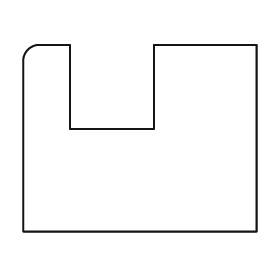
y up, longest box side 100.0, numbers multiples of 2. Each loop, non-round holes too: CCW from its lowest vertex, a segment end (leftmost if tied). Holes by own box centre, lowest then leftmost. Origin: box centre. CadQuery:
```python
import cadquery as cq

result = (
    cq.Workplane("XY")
    .moveTo(-50.0, -40.0)
    .lineTo(50.0, -40.0)
    .lineTo(50.0, 40.0)
    .lineTo(6.0, 40.0)
    .lineTo(6.0, 4.0)
    .lineTo(-30.0, 4.0)
    .lineTo(-30.0, 40.0)
    .lineTo(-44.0, 40.0)
    .threePointArc((-48.0, 38.0), (-50.0, 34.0))
    .close()
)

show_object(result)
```